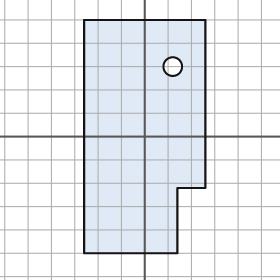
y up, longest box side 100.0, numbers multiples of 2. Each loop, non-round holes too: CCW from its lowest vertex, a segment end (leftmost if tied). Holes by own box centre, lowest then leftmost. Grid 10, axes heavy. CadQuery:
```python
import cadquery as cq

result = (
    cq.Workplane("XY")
    .moveTo(-26.0, -50.0)
    .lineTo(14.0, -50.0)
    .lineTo(14.0, -22.0)
    .lineTo(26.0, -22.0)
    .lineTo(26.0, 50.0)
    .lineTo(-26.0, 50.0)
    .close()
    .moveTo(12.0, 30.0)
    .circle(4.0)
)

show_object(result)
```